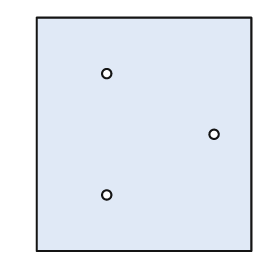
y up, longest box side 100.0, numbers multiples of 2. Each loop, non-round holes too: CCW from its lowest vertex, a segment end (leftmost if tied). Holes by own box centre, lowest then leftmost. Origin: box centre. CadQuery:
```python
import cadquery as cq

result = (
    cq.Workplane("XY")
    .moveTo(-46.0, -50.0)
    .lineTo(46.0, -50.0)
    .lineTo(46.0, 50.0)
    .lineTo(-46.0, 50.0)
    .close()
    .moveTo(-16.0, -26.0)
    .circle(2.0)
    .moveTo(30.0, 0.0)
    .circle(2.0)
    .moveTo(-16.0, 26.0)
    .circle(2.0)
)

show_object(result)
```